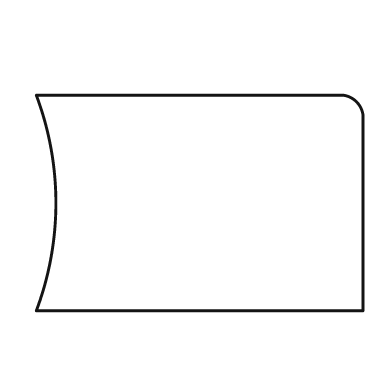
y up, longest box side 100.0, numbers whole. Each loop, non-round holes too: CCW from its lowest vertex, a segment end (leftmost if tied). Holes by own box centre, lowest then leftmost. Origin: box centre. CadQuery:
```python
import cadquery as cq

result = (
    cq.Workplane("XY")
    .moveTo(-50.0, -33.0)
    .lineTo(50.0, -33.0)
    .lineTo(50.0, 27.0)
    .threePointArc((48.0, 31.0), (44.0, 33.0))
    .lineTo(-50.0, 33.0)
    .threePointArc((-44.0, 0.0), (-50.0, -33.0))
    .close()
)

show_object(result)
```